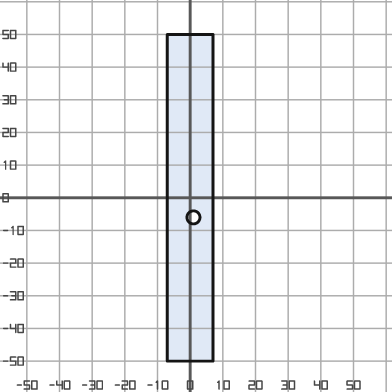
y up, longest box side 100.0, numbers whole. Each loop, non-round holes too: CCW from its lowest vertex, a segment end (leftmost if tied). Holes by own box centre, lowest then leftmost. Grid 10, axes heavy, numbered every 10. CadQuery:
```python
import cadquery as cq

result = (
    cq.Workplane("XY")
    .moveTo(-7.0, -50.0)
    .lineTo(7.0, -50.0)
    .lineTo(7.0, 50.0)
    .lineTo(-7.0, 50.0)
    .close()
    .moveTo(1.0, -6.0)
    .circle(2.0)
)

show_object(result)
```